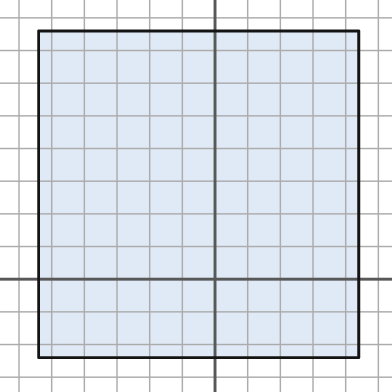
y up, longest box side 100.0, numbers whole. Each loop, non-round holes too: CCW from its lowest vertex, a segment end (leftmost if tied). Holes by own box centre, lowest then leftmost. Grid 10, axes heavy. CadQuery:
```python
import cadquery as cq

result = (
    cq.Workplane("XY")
    .moveTo(-54.0, -24.0)
    .lineTo(44.0, -24.0)
    .lineTo(44.0, 76.0)
    .lineTo(-54.0, 76.0)
    .close()
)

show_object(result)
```